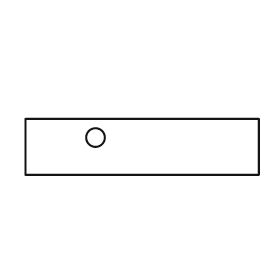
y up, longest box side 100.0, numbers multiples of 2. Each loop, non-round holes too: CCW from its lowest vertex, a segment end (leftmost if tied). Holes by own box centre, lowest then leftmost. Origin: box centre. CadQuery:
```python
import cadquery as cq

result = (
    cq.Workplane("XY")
    .moveTo(-50.0, -12.0)
    .lineTo(50.0, -12.0)
    .lineTo(50.0, 12.0)
    .lineTo(-50.0, 12.0)
    .close()
    .moveTo(-20.0, 4.0)
    .circle(4.0)
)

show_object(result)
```